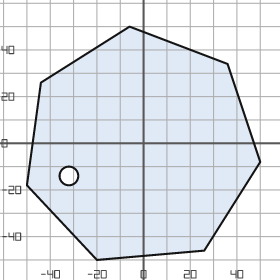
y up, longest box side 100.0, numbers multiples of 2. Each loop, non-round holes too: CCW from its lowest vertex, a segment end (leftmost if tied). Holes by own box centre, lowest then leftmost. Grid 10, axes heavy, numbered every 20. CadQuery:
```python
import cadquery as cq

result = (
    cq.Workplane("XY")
    .moveTo(-20.0, -50.0)
    .lineTo(26.0, -46.0)
    .lineTo(50.0, -8.0)
    .lineTo(36.0, 34.0)
    .lineTo(-6.0, 50.0)
    .lineTo(-44.0, 26.0)
    .lineTo(-50.0, -18.0)
    .close()
    .moveTo(-32.0, -14.0)
    .circle(4.0)
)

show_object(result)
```